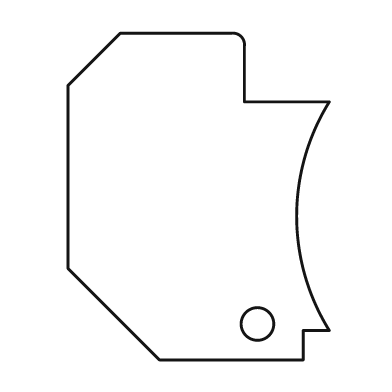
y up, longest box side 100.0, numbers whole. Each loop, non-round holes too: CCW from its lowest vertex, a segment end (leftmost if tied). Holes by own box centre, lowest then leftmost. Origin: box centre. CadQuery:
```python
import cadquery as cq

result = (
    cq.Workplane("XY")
    .moveTo(-12.0, -50.0)
    .lineTo(32.0, -50.0)
    .lineTo(32.0, -41.0)
    .lineTo(40.0, -41.0)
    .threePointArc((30.0, -6.0), (40.0, 29.0))
    .lineTo(14.0, 29.0)
    .lineTo(14.0, 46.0)
    .threePointArc((13.0, 49.0), (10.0, 50.0))
    .lineTo(-24.0, 50.0)
    .lineTo(-40.0, 34.0)
    .lineTo(-40.0, -22.0)
    .close()
    .moveTo(18.0, -39.0)
    .circle(5.0)
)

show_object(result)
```